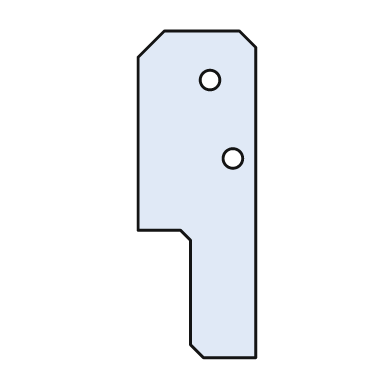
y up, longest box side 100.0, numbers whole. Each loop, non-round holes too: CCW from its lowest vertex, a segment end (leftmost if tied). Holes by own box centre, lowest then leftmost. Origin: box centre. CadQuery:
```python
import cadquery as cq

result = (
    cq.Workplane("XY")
    .moveTo(2.0, -50.0)
    .lineTo(18.0, -50.0)
    .lineTo(18.0, 45.0)
    .lineTo(13.0, 50.0)
    .lineTo(-10.0, 50.0)
    .lineTo(-18.0, 42.0)
    .lineTo(-18.0, -11.0)
    .lineTo(-5.0, -11.0)
    .lineTo(-2.0, -14.0)
    .lineTo(-2.0, -46.0)
    .close()
    .moveTo(11.0, 11.0)
    .circle(3.0)
    .moveTo(4.0, 35.0)
    .circle(3.0)
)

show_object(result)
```